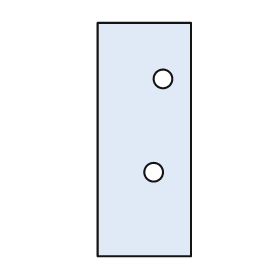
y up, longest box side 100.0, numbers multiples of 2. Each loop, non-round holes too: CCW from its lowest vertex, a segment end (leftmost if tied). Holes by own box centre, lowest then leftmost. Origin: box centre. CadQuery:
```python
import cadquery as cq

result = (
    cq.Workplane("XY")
    .moveTo(-20.0, -50.0)
    .lineTo(20.0, -50.0)
    .lineTo(20.0, 50.0)
    .lineTo(-20.0, 50.0)
    .close()
    .moveTo(4.0, -14.0)
    .circle(4.0)
    .moveTo(8.0, 26.0)
    .circle(4.0)
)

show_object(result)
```